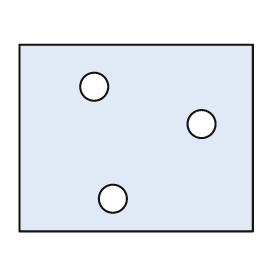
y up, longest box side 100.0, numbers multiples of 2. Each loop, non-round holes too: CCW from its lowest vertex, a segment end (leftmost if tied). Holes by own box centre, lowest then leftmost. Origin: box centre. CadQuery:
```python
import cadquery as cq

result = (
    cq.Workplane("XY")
    .moveTo(-50.0, -40.0)
    .lineTo(50.0, -40.0)
    .lineTo(50.0, 40.0)
    .lineTo(-50.0, 40.0)
    .close()
    .moveTo(-10.0, -26.0)
    .circle(6.0)
    .moveTo(28.0, 6.0)
    .circle(6.0)
    .moveTo(-18.0, 22.0)
    .circle(6.0)
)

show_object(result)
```